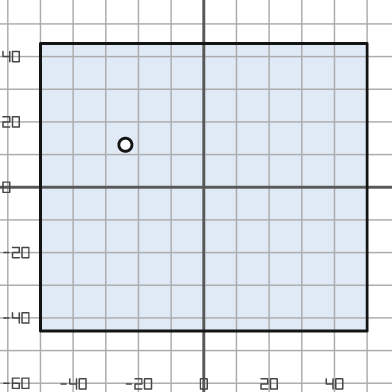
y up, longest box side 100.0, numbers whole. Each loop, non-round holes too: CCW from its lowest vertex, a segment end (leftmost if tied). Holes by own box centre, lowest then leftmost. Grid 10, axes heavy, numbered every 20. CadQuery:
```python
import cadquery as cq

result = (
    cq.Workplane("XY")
    .moveTo(-50.0, -44.0)
    .lineTo(50.0, -44.0)
    .lineTo(50.0, 44.0)
    .lineTo(-50.0, 44.0)
    .close()
    .moveTo(-24.0, 13.0)
    .circle(2.0)
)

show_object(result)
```